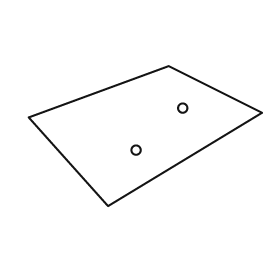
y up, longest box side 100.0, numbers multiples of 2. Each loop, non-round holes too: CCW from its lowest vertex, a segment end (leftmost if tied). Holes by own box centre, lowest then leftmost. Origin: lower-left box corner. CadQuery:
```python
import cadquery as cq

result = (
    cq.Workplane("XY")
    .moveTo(34.0, 0.0)
    .lineTo(100.0, 40.0)
    .lineTo(60.0, 60.0)
    .lineTo(0.0, 38.0)
    .close()
    .moveTo(46.0, 24.0)
    .circle(2.0)
    .moveTo(66.0, 42.0)
    .circle(2.0)
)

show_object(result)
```